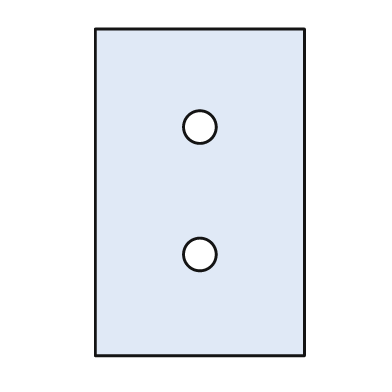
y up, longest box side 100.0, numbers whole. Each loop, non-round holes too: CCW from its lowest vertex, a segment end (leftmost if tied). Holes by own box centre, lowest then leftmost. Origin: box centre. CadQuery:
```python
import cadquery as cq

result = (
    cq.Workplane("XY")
    .moveTo(-32.0, -50.0)
    .lineTo(32.0, -50.0)
    .lineTo(32.0, 50.0)
    .lineTo(-32.0, 50.0)
    .close()
    .moveTo(0.0, -19.0)
    .circle(5.0)
    .moveTo(0.0, 20.0)
    .circle(5.0)
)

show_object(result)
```